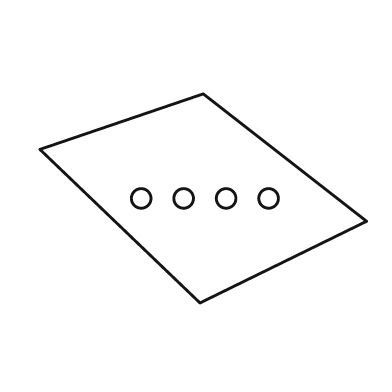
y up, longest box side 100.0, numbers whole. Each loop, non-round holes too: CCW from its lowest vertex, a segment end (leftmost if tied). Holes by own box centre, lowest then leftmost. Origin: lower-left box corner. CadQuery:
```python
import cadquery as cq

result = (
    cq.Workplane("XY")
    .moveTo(49.0, 0.0)
    .lineTo(100.0, 25.0)
    .lineTo(50.0, 64.0)
    .lineTo(0.0, 47.0)
    .close()
    .moveTo(31.0, 32.0)
    .circle(3.0)
    .moveTo(44.0, 32.0)
    .circle(3.0)
    .moveTo(57.0, 32.0)
    .circle(3.0)
    .moveTo(70.0, 32.0)
    .circle(3.0)
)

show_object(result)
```